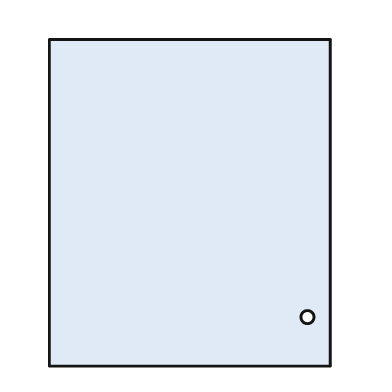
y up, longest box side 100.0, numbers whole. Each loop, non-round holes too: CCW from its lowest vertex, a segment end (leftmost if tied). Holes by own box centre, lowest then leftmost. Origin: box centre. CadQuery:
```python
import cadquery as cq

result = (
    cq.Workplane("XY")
    .moveTo(-43.0, -50.0)
    .lineTo(43.0, -50.0)
    .lineTo(43.0, 50.0)
    .lineTo(-43.0, 50.0)
    .close()
    .moveTo(36.0, -35.0)
    .circle(2.0)
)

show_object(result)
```